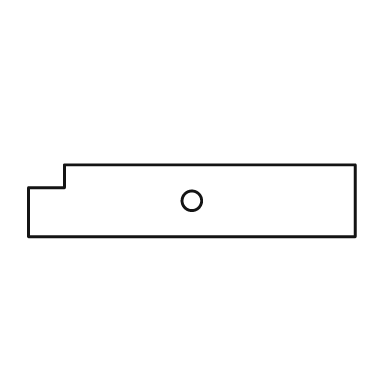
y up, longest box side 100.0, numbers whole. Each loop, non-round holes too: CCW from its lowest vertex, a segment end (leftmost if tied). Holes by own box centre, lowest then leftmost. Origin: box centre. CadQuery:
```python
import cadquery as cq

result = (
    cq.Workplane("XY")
    .moveTo(-50.0, -11.0)
    .lineTo(50.0, -11.0)
    .lineTo(50.0, 11.0)
    .lineTo(-39.0, 11.0)
    .lineTo(-39.0, 4.0)
    .lineTo(-50.0, 4.0)
    .close()
    .moveTo(0.0, 0.0)
    .circle(3.0)
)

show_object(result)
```